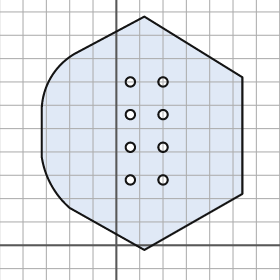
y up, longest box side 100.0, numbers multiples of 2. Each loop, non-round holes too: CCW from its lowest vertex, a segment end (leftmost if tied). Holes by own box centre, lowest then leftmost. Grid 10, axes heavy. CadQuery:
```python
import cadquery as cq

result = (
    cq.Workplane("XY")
    .moveTo(12.0, -2.0)
    .lineTo(54.0, 22.0)
    .lineTo(54.0, 72.0)
    .lineTo(12.0, 98.0)
    .lineTo(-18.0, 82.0)
    .threePointArc((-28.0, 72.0), (-32.0, 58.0))
    .lineTo(-32.0, 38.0)
    .threePointArc((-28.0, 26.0), (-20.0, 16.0))
    .close()
    .moveTo(6.0, 28.0)
    .circle(2.0)
    .moveTo(20.0, 28.0)
    .circle(2.0)
    .moveTo(6.0, 42.0)
    .circle(2.0)
    .moveTo(20.0, 42.0)
    .circle(2.0)
    .moveTo(6.0, 56.0)
    .circle(2.0)
    .moveTo(20.0, 56.0)
    .circle(2.0)
    .moveTo(6.0, 70.0)
    .circle(2.0)
    .moveTo(20.0, 70.0)
    .circle(2.0)
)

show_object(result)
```